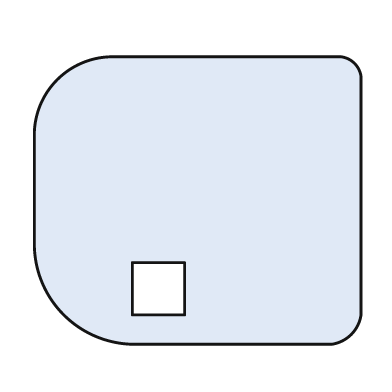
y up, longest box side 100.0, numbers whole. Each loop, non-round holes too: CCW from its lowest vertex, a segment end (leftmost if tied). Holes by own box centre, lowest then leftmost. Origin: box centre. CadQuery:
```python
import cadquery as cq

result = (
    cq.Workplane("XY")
    .moveTo(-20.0, -44.0)
    .lineTo(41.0, -44.0)
    .threePointArc((47.0, -41.0), (50.0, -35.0))
    .lineTo(50.0, 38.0)
    .threePointArc((48.0, 42.0), (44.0, 44.0))
    .lineTo(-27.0, 44.0)
    .threePointArc((-43.0, 37.0), (-50.0, 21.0))
    .lineTo(-50.0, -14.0)
    .threePointArc((-41.0, -35.0), (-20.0, -44.0))
    .close()
    .moveTo(-20.0, -35.0)
    .lineTo(-4.0, -35.0)
    .lineTo(-4.0, -19.0)
    .lineTo(-20.0, -19.0)
    .close()
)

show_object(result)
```